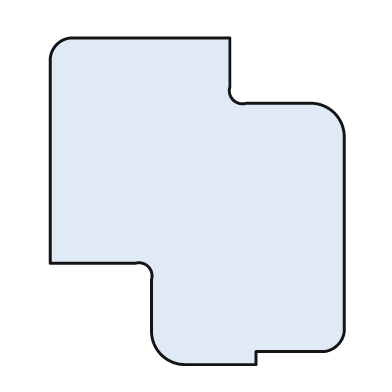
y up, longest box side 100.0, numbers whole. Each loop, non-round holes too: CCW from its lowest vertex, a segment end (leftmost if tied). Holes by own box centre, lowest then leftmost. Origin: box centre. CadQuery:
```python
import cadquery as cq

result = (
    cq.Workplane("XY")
    .moveTo(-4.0, -50.0)
    .lineTo(18.0, -50.0)
    .lineTo(18.0, -46.0)
    .lineTo(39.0, -46.0)
    .threePointArc((43.0, -44.0), (45.0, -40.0))
    .lineTo(45.0, 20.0)
    .threePointArc((42.0, 27.0), (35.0, 30.0))
    .lineTo(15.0, 30.0)
    .threePointArc((11.0, 31.0), (10.0, 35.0))
    .lineTo(10.0, 50.0)
    .lineTo(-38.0, 50.0)
    .threePointArc((-43.0, 48.0), (-45.0, 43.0))
    .lineTo(-45.0, -19.0)
    .lineTo(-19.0, -19.0)
    .threePointArc((-15.0, -20.0), (-14.0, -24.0))
    .lineTo(-14.0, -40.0)
    .threePointArc((-11.0, -47.0), (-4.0, -50.0))
    .close()
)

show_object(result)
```